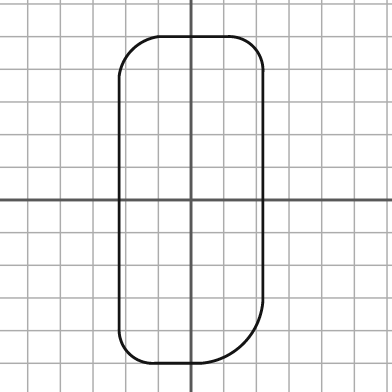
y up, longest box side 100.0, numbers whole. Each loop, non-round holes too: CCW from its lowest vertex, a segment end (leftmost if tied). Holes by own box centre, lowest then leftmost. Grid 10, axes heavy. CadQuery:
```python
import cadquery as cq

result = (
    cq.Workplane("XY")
    .moveTo(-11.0, -50.0)
    .lineTo(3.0, -50.0)
    .threePointArc((16.0, -44.0), (22.0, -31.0))
    .lineTo(22.0, 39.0)
    .threePointArc((19.0, 47.0), (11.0, 50.0))
    .lineTo(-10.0, 50.0)
    .threePointArc((-18.0, 46.0), (-22.0, 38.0))
    .lineTo(-22.0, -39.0)
    .threePointArc((-19.0, -47.0), (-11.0, -50.0))
    .close()
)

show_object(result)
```